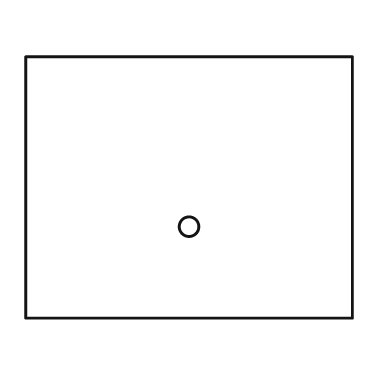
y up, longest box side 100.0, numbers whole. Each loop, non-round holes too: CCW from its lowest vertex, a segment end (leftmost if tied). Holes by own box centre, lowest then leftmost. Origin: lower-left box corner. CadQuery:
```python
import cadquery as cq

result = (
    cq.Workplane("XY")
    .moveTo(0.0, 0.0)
    .lineTo(100.0, 0.0)
    .lineTo(100.0, 80.0)
    .lineTo(0.0, 80.0)
    .close()
    .moveTo(50.0, 28.0)
    .circle(3.0)
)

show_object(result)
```